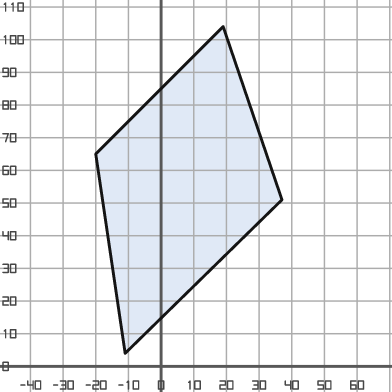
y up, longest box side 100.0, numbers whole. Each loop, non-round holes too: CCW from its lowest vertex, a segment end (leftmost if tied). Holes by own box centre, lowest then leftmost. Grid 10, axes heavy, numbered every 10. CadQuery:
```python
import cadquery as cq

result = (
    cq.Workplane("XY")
    .moveTo(-11.0, 4.0)
    .lineTo(37.0, 51.0)
    .lineTo(19.0, 104.0)
    .lineTo(-20.0, 65.0)
    .close()
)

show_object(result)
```